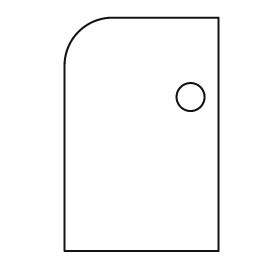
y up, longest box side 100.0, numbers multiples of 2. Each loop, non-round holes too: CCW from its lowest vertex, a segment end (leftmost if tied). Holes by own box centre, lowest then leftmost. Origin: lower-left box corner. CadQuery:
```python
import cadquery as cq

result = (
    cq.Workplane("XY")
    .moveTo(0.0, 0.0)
    .lineTo(66.0, 0.0)
    .lineTo(66.0, 100.0)
    .lineTo(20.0, 100.0)
    .threePointArc((6.0, 94.0), (0.0, 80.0))
    .close()
    .moveTo(54.0, 66.0)
    .circle(6.0)
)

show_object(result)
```